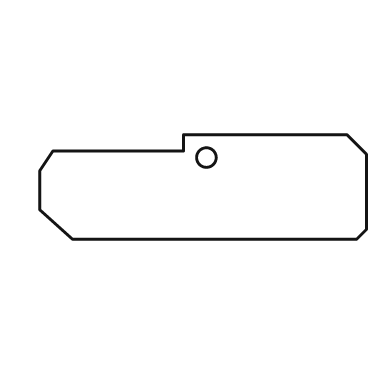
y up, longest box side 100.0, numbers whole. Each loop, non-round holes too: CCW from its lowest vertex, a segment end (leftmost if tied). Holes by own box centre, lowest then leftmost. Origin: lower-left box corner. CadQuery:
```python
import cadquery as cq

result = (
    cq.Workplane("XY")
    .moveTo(10.0, 0.0)
    .lineTo(97.0, 0.0)
    .lineTo(100.0, 3.0)
    .lineTo(100.0, 26.0)
    .lineTo(94.0, 32.0)
    .lineTo(44.0, 32.0)
    .lineTo(44.0, 27.0)
    .lineTo(4.0, 27.0)
    .lineTo(0.0, 21.0)
    .lineTo(0.0, 9.0)
    .close()
    .moveTo(51.0, 25.0)
    .circle(3.0)
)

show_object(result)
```